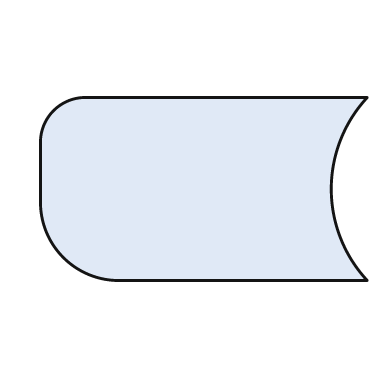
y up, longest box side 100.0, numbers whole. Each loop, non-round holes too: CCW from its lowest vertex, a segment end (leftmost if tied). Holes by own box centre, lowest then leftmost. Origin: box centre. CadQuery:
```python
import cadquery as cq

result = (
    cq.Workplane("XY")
    .moveTo(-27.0, -28.0)
    .lineTo(50.0, -28.0)
    .threePointArc((39.0, 0.0), (50.0, 28.0))
    .lineTo(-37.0, 28.0)
    .threePointArc((-46.0, 24.0), (-50.0, 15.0))
    .lineTo(-50.0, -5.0)
    .threePointArc((-43.0, -21.0), (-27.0, -28.0))
    .close()
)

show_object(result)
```